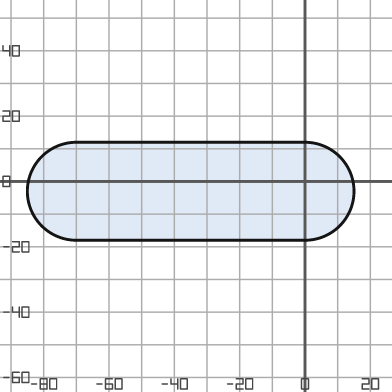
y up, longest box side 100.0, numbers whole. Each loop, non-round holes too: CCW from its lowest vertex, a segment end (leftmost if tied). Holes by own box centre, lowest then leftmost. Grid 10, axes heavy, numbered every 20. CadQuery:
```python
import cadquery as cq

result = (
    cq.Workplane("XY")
    .moveTo(-70.0, -18.0)
    .lineTo(0.0, -18.0)
    .threePointArc((15.0, -3.0), (0.0, 12.0))
    .lineTo(-70.0, 12.0)
    .threePointArc((-85.0, -3.0), (-70.0, -18.0))
    .close()
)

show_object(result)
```